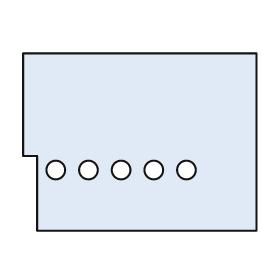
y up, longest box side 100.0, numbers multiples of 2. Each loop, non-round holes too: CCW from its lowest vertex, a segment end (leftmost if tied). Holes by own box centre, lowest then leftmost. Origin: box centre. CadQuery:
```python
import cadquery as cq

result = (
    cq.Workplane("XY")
    .moveTo(-44.0, -38.0)
    .lineTo(50.0, -38.0)
    .lineTo(50.0, 38.0)
    .lineTo(-50.0, 38.0)
    .lineTo(-50.0, -6.0)
    .lineTo(-44.0, -6.0)
    .close()
    .moveTo(-36.0, -12.0)
    .circle(4.0)
    .moveTo(-22.0, -12.0)
    .circle(4.0)
    .moveTo(-8.0, -12.0)
    .circle(4.0)
    .moveTo(6.0, -12.0)
    .circle(4.0)
    .moveTo(20.0, -12.0)
    .circle(4.0)
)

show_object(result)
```